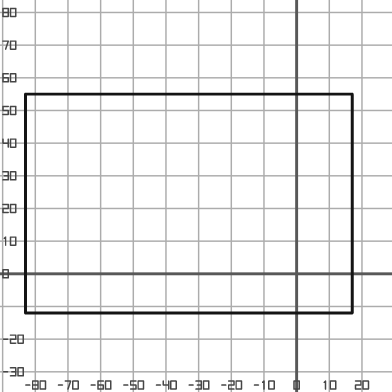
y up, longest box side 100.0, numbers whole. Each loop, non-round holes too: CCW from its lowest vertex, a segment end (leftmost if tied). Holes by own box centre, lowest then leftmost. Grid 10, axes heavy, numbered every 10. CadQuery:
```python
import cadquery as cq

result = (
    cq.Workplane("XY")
    .moveTo(-83.0, -12.0)
    .lineTo(17.0, -12.0)
    .lineTo(17.0, 55.0)
    .lineTo(-83.0, 55.0)
    .close()
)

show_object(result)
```